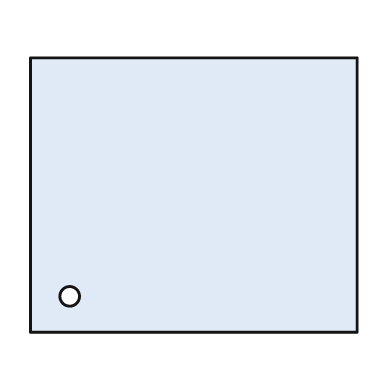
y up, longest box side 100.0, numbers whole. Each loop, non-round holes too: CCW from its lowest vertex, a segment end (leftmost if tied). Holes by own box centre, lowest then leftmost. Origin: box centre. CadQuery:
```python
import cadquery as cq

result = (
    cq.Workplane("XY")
    .moveTo(-50.0, -42.0)
    .lineTo(50.0, -42.0)
    .lineTo(50.0, 42.0)
    .lineTo(-50.0, 42.0)
    .close()
    .moveTo(-38.0, -31.0)
    .circle(3.0)
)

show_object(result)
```